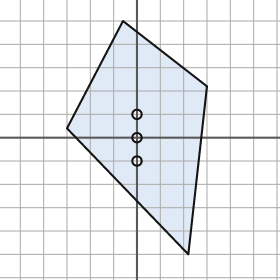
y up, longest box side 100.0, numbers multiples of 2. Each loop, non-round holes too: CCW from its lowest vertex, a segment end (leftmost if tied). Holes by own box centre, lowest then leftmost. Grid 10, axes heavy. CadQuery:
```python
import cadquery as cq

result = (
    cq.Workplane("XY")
    .moveTo(22.0, -50.0)
    .lineTo(30.0, 22.0)
    .lineTo(-6.0, 50.0)
    .lineTo(-30.0, 4.0)
    .close()
    .moveTo(0.0, -10.0)
    .circle(2.0)
    .moveTo(0.0, 0.0)
    .circle(2.0)
    .moveTo(0.0, 10.0)
    .circle(2.0)
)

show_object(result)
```